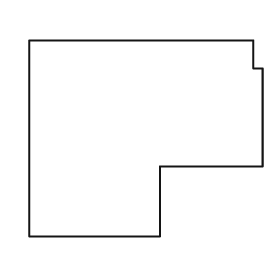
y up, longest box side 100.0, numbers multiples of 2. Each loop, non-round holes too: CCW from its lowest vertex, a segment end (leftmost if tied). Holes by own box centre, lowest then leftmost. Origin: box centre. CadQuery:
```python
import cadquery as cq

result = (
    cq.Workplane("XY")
    .moveTo(-50.0, -42.0)
    .lineTo(6.0, -42.0)
    .lineTo(6.0, -12.0)
    .lineTo(50.0, -12.0)
    .lineTo(50.0, 30.0)
    .lineTo(46.0, 30.0)
    .lineTo(46.0, 42.0)
    .lineTo(-50.0, 42.0)
    .close()
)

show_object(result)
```